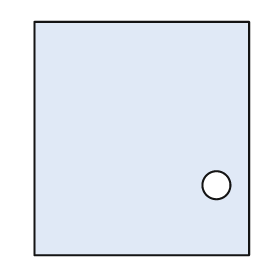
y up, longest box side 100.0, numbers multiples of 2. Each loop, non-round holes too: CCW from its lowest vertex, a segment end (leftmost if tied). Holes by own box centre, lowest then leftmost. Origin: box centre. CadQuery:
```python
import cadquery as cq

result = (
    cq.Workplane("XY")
    .moveTo(-46.0, -50.0)
    .lineTo(46.0, -50.0)
    .lineTo(46.0, 50.0)
    .lineTo(-46.0, 50.0)
    .close()
    .moveTo(32.0, -20.0)
    .circle(6.0)
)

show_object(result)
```